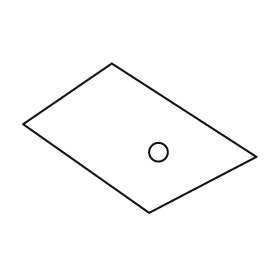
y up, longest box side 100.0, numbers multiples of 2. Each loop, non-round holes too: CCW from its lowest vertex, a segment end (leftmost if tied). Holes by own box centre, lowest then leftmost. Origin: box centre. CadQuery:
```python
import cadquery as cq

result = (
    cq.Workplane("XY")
    .moveTo(4.0, -32.0)
    .lineTo(50.0, -8.0)
    .lineTo(-12.0, 32.0)
    .lineTo(-50.0, 6.0)
    .close()
    .moveTo(8.0, -6.0)
    .circle(4.0)
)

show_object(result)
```